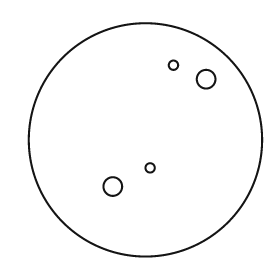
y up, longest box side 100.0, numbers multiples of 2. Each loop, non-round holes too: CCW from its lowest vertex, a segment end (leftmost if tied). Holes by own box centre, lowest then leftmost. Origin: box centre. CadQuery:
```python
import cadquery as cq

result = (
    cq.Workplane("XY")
    .moveTo(0.0, 0.0)
    .circle(50.0)
    .moveTo(-14.0, -20.0)
    .circle(4.0)
    .moveTo(2.0, -12.0)
    .circle(2.0)
    .moveTo(26.0, 26.0)
    .circle(4.0)
    .moveTo(12.0, 32.0)
    .circle(2.0)
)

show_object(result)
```